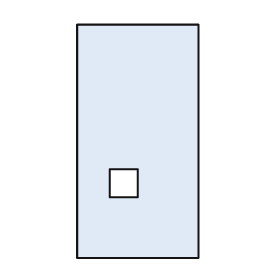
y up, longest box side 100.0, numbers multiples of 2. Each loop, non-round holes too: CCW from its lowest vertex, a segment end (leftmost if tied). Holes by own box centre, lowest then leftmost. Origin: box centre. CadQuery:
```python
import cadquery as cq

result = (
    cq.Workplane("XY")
    .moveTo(-26.0, -50.0)
    .lineTo(26.0, -50.0)
    .lineTo(26.0, 50.0)
    .lineTo(-26.0, 50.0)
    .close()
    .moveTo(-12.0, -24.0)
    .lineTo(0.0, -24.0)
    .lineTo(0.0, -12.0)
    .lineTo(-12.0, -12.0)
    .close()
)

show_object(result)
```